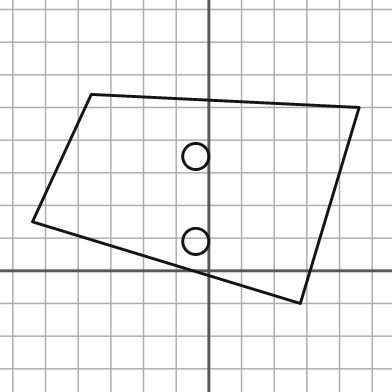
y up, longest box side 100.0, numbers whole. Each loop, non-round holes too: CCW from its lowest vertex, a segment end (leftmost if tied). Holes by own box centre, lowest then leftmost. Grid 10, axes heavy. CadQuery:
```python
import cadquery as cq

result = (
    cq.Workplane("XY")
    .moveTo(28.0, -10.0)
    .lineTo(46.0, 50.0)
    .lineTo(-36.0, 54.0)
    .lineTo(-54.0, 15.0)
    .close()
    .moveTo(-4.0, 9.0)
    .circle(4.0)
    .moveTo(-4.0, 35.0)
    .circle(4.0)
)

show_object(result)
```